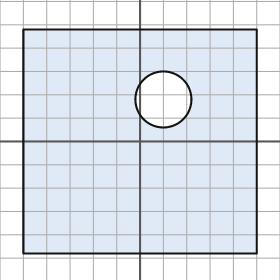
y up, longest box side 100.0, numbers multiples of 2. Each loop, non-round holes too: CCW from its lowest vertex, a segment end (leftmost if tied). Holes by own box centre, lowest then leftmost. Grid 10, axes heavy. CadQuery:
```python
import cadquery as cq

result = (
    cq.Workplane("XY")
    .moveTo(-50.0, -48.0)
    .lineTo(50.0, -48.0)
    .lineTo(50.0, 48.0)
    .lineTo(-50.0, 48.0)
    .close()
    .moveTo(10.0, 18.0)
    .circle(12.0)
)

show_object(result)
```